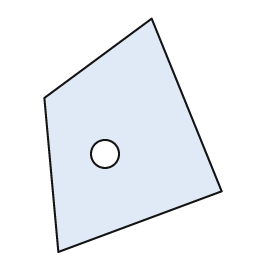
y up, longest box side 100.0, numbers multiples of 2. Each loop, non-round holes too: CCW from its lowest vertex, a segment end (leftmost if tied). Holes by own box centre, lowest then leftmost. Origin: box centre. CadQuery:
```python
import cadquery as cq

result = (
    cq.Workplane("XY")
    .moveTo(-32.0, -50.0)
    .lineTo(38.0, -24.0)
    .lineTo(8.0, 50.0)
    .lineTo(-38.0, 16.0)
    .close()
    .moveTo(-12.0, -8.0)
    .circle(6.0)
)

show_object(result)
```